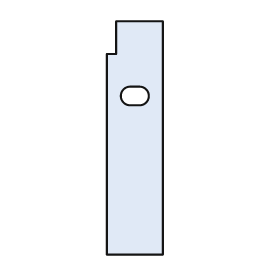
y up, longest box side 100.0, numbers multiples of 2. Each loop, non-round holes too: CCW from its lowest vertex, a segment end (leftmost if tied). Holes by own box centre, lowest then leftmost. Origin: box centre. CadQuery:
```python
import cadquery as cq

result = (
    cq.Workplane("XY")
    .moveTo(-12.0, -50.0)
    .lineTo(12.0, -50.0)
    .lineTo(12.0, 50.0)
    .lineTo(-8.0, 50.0)
    .lineTo(-8.0, 36.0)
    .lineTo(-12.0, 36.0)
    .close()
    .moveTo(-2.0, 14.0)
    .lineTo(2.0, 14.0)
    .threePointArc((6.0, 18.0), (2.0, 22.0))
    .lineTo(-2.0, 22.0)
    .threePointArc((-6.0, 18.0), (-2.0, 14.0))
    .close()
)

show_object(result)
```